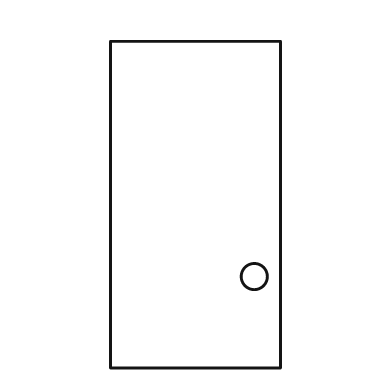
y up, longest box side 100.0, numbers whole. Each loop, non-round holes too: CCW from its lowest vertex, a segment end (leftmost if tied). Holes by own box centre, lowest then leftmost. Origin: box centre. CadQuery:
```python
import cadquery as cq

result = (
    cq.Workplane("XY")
    .moveTo(-26.0, -50.0)
    .lineTo(26.0, -50.0)
    .lineTo(26.0, 50.0)
    .lineTo(-26.0, 50.0)
    .close()
    .moveTo(18.0, -22.0)
    .circle(4.0)
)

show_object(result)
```